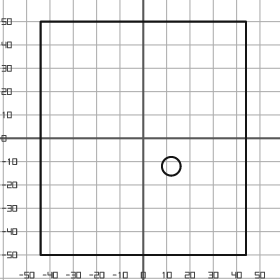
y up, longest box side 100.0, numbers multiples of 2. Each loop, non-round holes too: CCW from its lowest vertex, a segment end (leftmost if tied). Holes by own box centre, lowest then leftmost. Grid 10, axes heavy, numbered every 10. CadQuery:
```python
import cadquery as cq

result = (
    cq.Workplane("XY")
    .moveTo(-44.0, -50.0)
    .lineTo(44.0, -50.0)
    .lineTo(44.0, 50.0)
    .lineTo(-44.0, 50.0)
    .close()
    .moveTo(12.0, -12.0)
    .circle(4.0)
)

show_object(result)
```